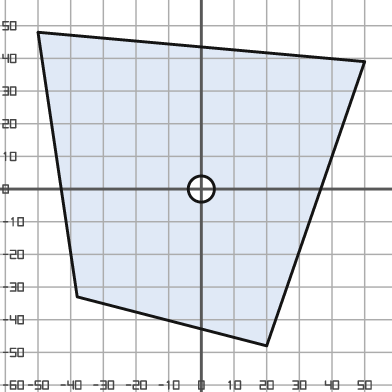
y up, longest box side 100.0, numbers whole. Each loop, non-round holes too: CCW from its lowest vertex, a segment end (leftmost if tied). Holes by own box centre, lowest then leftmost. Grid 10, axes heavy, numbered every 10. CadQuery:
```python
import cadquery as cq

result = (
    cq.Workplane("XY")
    .moveTo(20.0, -48.0)
    .lineTo(50.0, 39.0)
    .lineTo(-50.0, 48.0)
    .lineTo(-38.0, -33.0)
    .close()
    .moveTo(0.0, 0.0)
    .circle(4.0)
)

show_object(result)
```